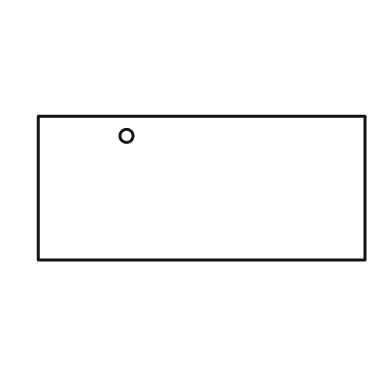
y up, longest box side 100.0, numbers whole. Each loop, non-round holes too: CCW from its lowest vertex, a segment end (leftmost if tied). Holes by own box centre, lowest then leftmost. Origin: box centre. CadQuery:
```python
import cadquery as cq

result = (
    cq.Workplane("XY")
    .moveTo(-50.0, -22.0)
    .lineTo(50.0, -22.0)
    .lineTo(50.0, 22.0)
    .lineTo(-50.0, 22.0)
    .close()
    .moveTo(-23.0, 16.0)
    .circle(2.0)
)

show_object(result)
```